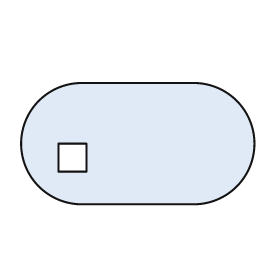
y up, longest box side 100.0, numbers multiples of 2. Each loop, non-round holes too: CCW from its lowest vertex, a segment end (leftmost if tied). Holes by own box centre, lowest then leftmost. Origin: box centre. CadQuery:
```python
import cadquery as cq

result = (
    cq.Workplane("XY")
    .moveTo(-24.0, -26.0)
    .lineTo(24.0, -26.0)
    .threePointArc((50.0, 0.0), (24.0, 26.0))
    .lineTo(-24.0, 26.0)
    .threePointArc((-50.0, 0.0), (-24.0, -26.0))
    .close()
    .moveTo(-34.0, -12.0)
    .lineTo(-22.0, -12.0)
    .lineTo(-22.0, 0.0)
    .lineTo(-34.0, 0.0)
    .close()
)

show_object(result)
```